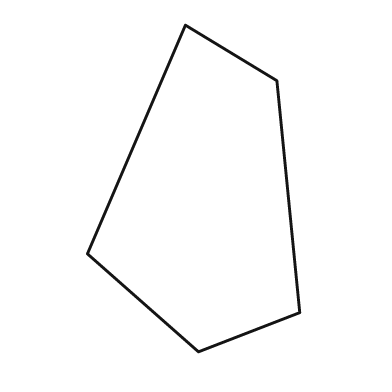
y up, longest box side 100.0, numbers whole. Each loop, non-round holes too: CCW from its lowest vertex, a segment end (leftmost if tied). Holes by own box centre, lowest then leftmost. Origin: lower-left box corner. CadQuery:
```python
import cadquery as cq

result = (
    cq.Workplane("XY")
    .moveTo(34.0, 0.0)
    .lineTo(65.0, 12.0)
    .lineTo(58.0, 83.0)
    .lineTo(30.0, 100.0)
    .lineTo(0.0, 30.0)
    .close()
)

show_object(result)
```